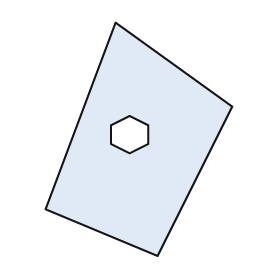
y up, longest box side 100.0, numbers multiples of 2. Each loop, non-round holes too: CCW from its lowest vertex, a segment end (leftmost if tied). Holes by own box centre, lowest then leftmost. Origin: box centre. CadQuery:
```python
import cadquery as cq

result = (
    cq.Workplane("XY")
    .moveTo(8.0, -50.0)
    .lineTo(40.0, 14.0)
    .lineTo(-10.0, 50.0)
    .lineTo(-40.0, -30.0)
    .close()
    .moveTo(-4.0, -6.0)
    .lineTo(4.0, -2.0)
    .lineTo(4.0, 6.0)
    .lineTo(-4.0, 10.0)
    .lineTo(-12.0, 6.0)
    .lineTo(-12.0, -2.0)
    .close()
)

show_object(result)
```